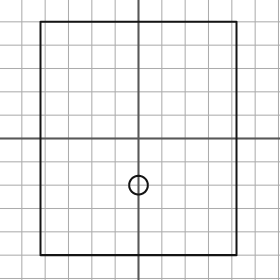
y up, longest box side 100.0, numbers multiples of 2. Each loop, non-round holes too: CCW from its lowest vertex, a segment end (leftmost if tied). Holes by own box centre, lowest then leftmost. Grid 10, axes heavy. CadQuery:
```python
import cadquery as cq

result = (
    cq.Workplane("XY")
    .moveTo(-42.0, -50.0)
    .lineTo(42.0, -50.0)
    .lineTo(42.0, 50.0)
    .lineTo(-42.0, 50.0)
    .close()
    .moveTo(0.0, -20.0)
    .circle(4.0)
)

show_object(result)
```